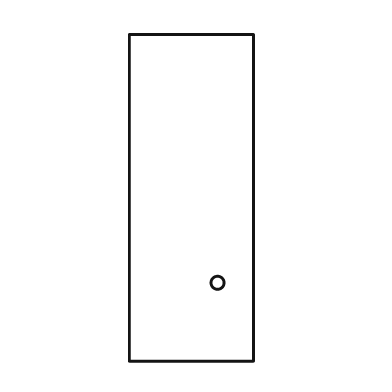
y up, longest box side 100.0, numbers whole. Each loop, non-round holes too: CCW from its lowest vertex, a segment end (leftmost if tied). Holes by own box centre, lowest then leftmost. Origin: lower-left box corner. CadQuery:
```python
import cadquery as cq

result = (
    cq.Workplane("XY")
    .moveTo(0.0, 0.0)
    .lineTo(38.0, 0.0)
    .lineTo(38.0, 100.0)
    .lineTo(0.0, 100.0)
    .close()
    .moveTo(27.0, 24.0)
    .circle(2.0)
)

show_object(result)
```